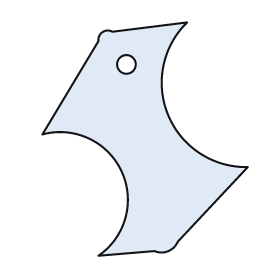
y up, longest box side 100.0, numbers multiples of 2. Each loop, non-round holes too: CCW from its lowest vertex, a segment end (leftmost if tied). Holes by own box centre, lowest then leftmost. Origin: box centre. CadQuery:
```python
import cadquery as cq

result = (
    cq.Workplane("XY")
    .moveTo(-20.0, -50.0)
    .lineTo(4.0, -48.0)
    .threePointArc((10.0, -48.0), (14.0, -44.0))
    .lineTo(44.0, -12.0)
    .threePointArc((10.0, 10.0), (18.0, 50.0))
    .lineTo(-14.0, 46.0)
    .threePointArc((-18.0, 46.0), (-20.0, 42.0))
    .lineTo(-44.0, 2.0)
    .threePointArc((-10.0, -14.0), (-20.0, -50.0))
    .close()
    .moveTo(-8.0, 32.0)
    .circle(4.0)
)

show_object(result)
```